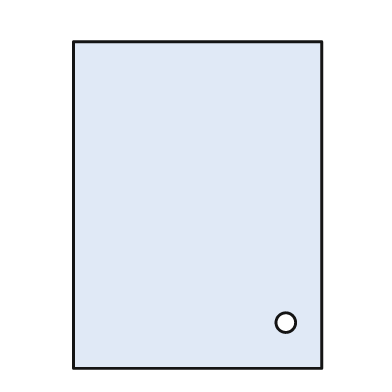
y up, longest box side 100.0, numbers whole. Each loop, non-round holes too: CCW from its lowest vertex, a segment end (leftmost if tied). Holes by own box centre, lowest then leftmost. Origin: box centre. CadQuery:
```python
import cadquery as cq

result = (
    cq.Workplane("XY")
    .moveTo(-38.0, -50.0)
    .lineTo(38.0, -50.0)
    .lineTo(38.0, 50.0)
    .lineTo(-38.0, 50.0)
    .close()
    .moveTo(27.0, -36.0)
    .circle(3.0)
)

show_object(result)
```